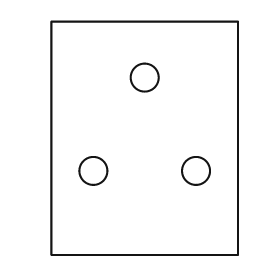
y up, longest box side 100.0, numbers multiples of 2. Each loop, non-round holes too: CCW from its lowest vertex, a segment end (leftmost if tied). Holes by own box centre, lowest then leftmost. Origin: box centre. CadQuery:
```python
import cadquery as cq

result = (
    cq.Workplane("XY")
    .moveTo(-40.0, -50.0)
    .lineTo(40.0, -50.0)
    .lineTo(40.0, 50.0)
    .lineTo(-40.0, 50.0)
    .close()
    .moveTo(-22.0, -14.0)
    .circle(6.0)
    .moveTo(22.0, -14.0)
    .circle(6.0)
    .moveTo(0.0, 26.0)
    .circle(6.0)
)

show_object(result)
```